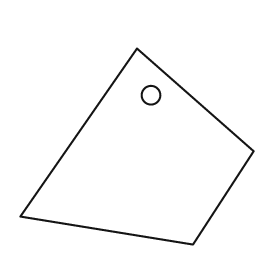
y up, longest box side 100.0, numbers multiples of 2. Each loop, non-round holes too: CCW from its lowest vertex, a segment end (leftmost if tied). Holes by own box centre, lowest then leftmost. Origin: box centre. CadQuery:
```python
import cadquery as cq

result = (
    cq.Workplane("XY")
    .moveTo(24.0, -42.0)
    .lineTo(50.0, -2.0)
    .lineTo(0.0, 42.0)
    .lineTo(-50.0, -30.0)
    .close()
    .moveTo(6.0, 22.0)
    .circle(4.0)
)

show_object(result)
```